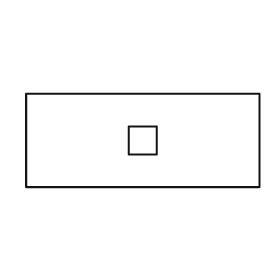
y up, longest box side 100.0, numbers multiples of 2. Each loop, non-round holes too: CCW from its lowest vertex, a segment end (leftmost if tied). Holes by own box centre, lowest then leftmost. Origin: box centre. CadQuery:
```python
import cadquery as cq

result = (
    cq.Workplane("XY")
    .moveTo(-50.0, -20.0)
    .lineTo(50.0, -20.0)
    .lineTo(50.0, 20.0)
    .lineTo(-50.0, 20.0)
    .close()
    .moveTo(-6.0, -6.0)
    .lineTo(6.0, -6.0)
    .lineTo(6.0, 6.0)
    .lineTo(-6.0, 6.0)
    .close()
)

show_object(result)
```